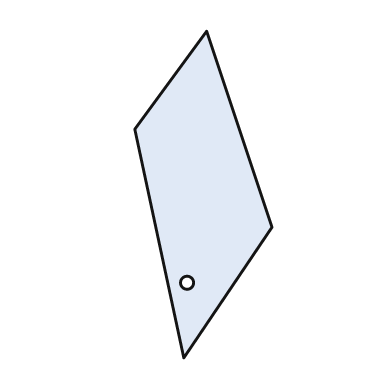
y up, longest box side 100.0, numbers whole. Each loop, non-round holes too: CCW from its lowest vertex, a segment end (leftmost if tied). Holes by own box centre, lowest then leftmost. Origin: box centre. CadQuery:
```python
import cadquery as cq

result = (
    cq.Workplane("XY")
    .moveTo(-6.0, -50.0)
    .lineTo(21.0, -10.0)
    .lineTo(1.0, 50.0)
    .lineTo(-21.0, 20.0)
    .close()
    .moveTo(-5.0, -27.0)
    .circle(2.0)
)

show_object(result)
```